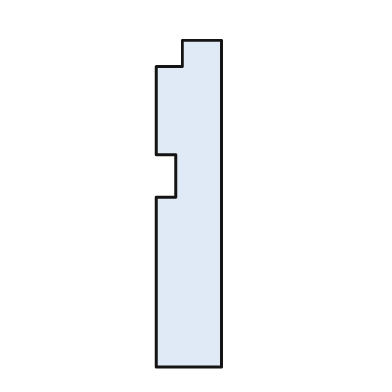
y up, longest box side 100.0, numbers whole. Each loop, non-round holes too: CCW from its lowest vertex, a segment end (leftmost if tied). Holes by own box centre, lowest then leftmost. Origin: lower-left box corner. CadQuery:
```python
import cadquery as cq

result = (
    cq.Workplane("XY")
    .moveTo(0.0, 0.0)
    .lineTo(20.0, 0.0)
    .lineTo(20.0, 100.0)
    .lineTo(8.0, 100.0)
    .lineTo(8.0, 92.0)
    .lineTo(0.0, 92.0)
    .lineTo(0.0, 65.0)
    .lineTo(6.0, 65.0)
    .lineTo(6.0, 52.0)
    .lineTo(0.0, 52.0)
    .close()
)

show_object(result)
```